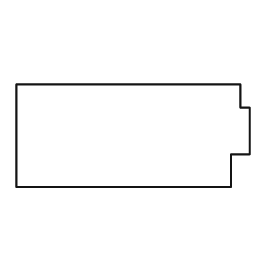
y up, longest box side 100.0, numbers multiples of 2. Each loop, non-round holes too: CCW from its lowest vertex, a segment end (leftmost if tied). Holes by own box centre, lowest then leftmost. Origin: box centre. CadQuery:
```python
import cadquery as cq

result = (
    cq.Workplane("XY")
    .moveTo(-50.0, -22.0)
    .lineTo(42.0, -22.0)
    .lineTo(42.0, -8.0)
    .lineTo(50.0, -8.0)
    .lineTo(50.0, 12.0)
    .lineTo(46.0, 12.0)
    .lineTo(46.0, 22.0)
    .lineTo(-50.0, 22.0)
    .close()
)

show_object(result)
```